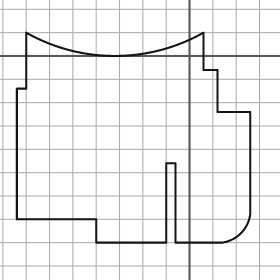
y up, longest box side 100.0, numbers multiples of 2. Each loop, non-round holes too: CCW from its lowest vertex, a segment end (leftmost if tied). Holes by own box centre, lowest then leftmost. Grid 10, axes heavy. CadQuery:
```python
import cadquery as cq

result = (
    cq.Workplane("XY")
    .moveTo(-40.0, -80.0)
    .lineTo(-10.0, -80.0)
    .lineTo(-10.0, -46.0)
    .lineTo(-6.0, -46.0)
    .lineTo(-6.0, -80.0)
    .lineTo(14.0, -80.0)
    .threePointArc((22.0, -76.0), (26.0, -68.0))
    .lineTo(26.0, -24.0)
    .lineTo(12.0, -24.0)
    .lineTo(12.0, -6.0)
    .lineTo(6.0, -6.0)
    .lineTo(6.0, 10.0)
    .threePointArc((-32.0, 0.0), (-70.0, 10.0))
    .lineTo(-70.0, -14.0)
    .lineTo(-74.0, -14.0)
    .lineTo(-74.0, -70.0)
    .lineTo(-40.0, -70.0)
    .close()
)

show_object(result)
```